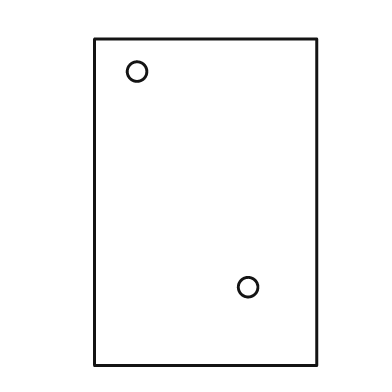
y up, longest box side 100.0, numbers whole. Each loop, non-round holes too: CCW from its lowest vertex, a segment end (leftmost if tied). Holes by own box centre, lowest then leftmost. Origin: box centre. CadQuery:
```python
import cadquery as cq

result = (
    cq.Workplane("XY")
    .moveTo(-34.0, -50.0)
    .lineTo(34.0, -50.0)
    .lineTo(34.0, 50.0)
    .lineTo(-34.0, 50.0)
    .close()
    .moveTo(13.0, -26.0)
    .circle(3.0)
    .moveTo(-21.0, 40.0)
    .circle(3.0)
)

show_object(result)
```